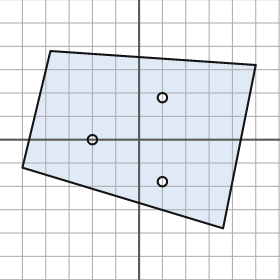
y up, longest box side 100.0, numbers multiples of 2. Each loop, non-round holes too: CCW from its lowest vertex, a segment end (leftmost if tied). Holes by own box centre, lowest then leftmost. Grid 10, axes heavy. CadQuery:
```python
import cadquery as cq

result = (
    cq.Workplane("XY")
    .moveTo(36.0, -38.0)
    .lineTo(50.0, 32.0)
    .lineTo(-38.0, 38.0)
    .lineTo(-50.0, -12.0)
    .close()
    .moveTo(10.0, -18.0)
    .circle(2.0)
    .moveTo(-20.0, 0.0)
    .circle(2.0)
    .moveTo(10.0, 18.0)
    .circle(2.0)
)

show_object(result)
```